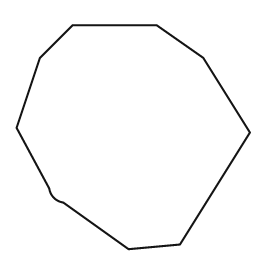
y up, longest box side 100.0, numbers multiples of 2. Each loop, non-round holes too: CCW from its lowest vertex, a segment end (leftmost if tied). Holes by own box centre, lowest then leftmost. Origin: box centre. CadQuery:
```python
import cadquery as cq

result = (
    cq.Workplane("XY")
    .moveTo(-2.0, -48.0)
    .lineTo(20.0, -46.0)
    .lineTo(50.0, 2.0)
    .lineTo(30.0, 34.0)
    .lineTo(10.0, 48.0)
    .lineTo(-26.0, 48.0)
    .lineTo(-40.0, 34.0)
    .lineTo(-50.0, 4.0)
    .lineTo(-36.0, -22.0)
    .threePointArc((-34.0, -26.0), (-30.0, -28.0))
    .close()
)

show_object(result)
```